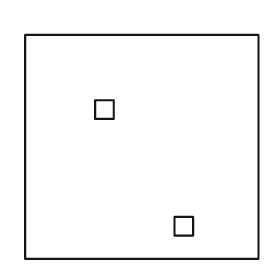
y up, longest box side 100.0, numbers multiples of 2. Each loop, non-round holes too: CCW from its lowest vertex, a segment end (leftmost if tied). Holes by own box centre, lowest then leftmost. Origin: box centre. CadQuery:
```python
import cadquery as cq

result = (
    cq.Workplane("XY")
    .moveTo(-50.0, -48.0)
    .lineTo(50.0, -48.0)
    .lineTo(50.0, 48.0)
    .lineTo(-50.0, 48.0)
    .close()
    .moveTo(14.0, -38.0)
    .lineTo(22.0, -38.0)
    .lineTo(22.0, -30.0)
    .lineTo(14.0, -30.0)
    .close()
    .moveTo(-20.0, 12.0)
    .lineTo(-12.0, 12.0)
    .lineTo(-12.0, 20.0)
    .lineTo(-20.0, 20.0)
    .close()
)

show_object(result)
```